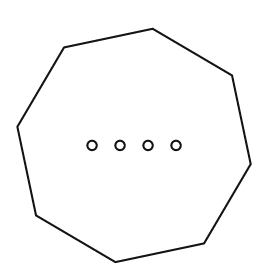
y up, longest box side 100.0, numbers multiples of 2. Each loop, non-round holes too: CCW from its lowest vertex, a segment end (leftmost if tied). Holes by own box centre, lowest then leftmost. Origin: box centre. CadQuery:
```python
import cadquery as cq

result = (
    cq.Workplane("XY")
    .moveTo(-8.0, -50.0)
    .lineTo(30.0, -42.0)
    .lineTo(50.0, -8.0)
    .lineTo(42.0, 30.0)
    .lineTo(8.0, 50.0)
    .lineTo(-30.0, 42.0)
    .lineTo(-50.0, 8.0)
    .lineTo(-42.0, -30.0)
    .close()
    .moveTo(-18.0, 0.0)
    .circle(2.0)
    .moveTo(-6.0, 0.0)
    .circle(2.0)
    .moveTo(6.0, 0.0)
    .circle(2.0)
    .moveTo(18.0, 0.0)
    .circle(2.0)
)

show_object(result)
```